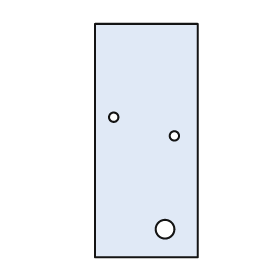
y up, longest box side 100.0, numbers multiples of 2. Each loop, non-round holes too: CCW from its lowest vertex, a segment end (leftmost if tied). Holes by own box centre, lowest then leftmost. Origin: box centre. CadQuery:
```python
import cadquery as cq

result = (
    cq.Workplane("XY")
    .moveTo(-22.0, -50.0)
    .lineTo(22.0, -50.0)
    .lineTo(22.0, 50.0)
    .lineTo(-22.0, 50.0)
    .close()
    .moveTo(8.0, -38.0)
    .circle(4.0)
    .moveTo(12.0, 2.0)
    .circle(2.0)
    .moveTo(-14.0, 10.0)
    .circle(2.0)
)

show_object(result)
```